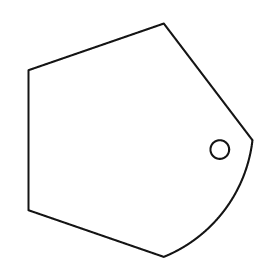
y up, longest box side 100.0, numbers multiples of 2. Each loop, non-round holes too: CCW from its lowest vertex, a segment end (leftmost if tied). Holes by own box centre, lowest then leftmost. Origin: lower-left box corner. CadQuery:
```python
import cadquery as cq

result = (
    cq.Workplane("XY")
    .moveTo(58.0, 0.0)
    .threePointArc((84.0, 20.0), (96.0, 50.0))
    .lineTo(58.0, 100.0)
    .lineTo(0.0, 80.0)
    .lineTo(0.0, 20.0)
    .close()
    .moveTo(82.0, 46.0)
    .circle(4.0)
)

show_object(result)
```